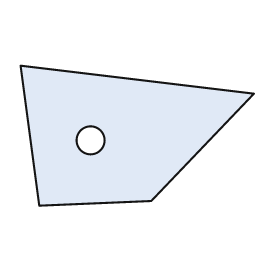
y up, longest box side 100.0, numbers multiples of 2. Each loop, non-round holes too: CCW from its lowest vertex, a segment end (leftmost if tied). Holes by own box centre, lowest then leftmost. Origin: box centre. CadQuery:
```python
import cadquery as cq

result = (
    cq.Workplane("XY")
    .moveTo(-42.0, -30.0)
    .lineTo(6.0, -28.0)
    .lineTo(50.0, 18.0)
    .lineTo(-50.0, 30.0)
    .close()
    .moveTo(-20.0, -2.0)
    .circle(6.0)
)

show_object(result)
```